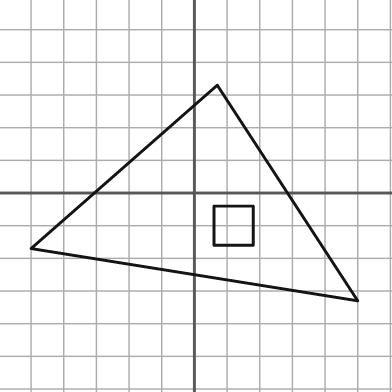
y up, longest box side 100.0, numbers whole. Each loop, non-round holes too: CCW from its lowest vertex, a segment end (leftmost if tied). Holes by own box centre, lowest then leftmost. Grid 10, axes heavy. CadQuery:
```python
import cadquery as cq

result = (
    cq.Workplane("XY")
    .moveTo(50.0, -33.0)
    .lineTo(7.0, 33.0)
    .lineTo(-50.0, -17.0)
    .close()
    .moveTo(6.0, -16.0)
    .lineTo(18.0, -16.0)
    .lineTo(18.0, -4.0)
    .lineTo(6.0, -4.0)
    .close()
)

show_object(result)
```